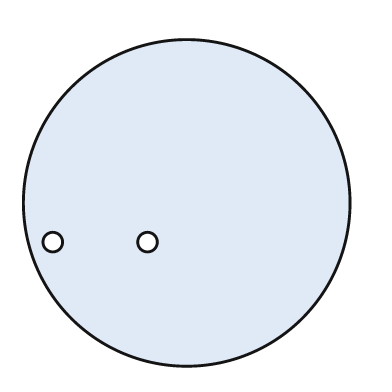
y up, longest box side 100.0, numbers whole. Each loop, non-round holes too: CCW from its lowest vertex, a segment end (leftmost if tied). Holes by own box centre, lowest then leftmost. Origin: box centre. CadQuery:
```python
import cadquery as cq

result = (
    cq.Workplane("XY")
    .moveTo(0.0, 0.0)
    .circle(50.0)
    .moveTo(-41.0, -12.0)
    .circle(3.0)
    .moveTo(-12.0, -12.0)
    .circle(3.0)
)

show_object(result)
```